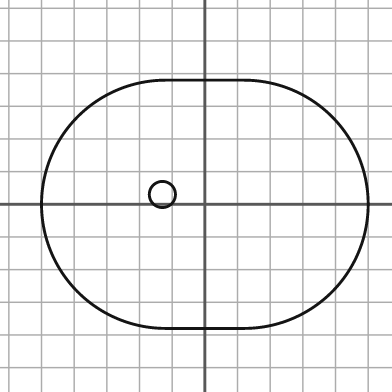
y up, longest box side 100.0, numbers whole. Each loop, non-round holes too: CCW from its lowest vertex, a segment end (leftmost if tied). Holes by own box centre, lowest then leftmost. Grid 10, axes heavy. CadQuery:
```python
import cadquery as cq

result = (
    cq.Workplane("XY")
    .moveTo(-12.0, -38.0)
    .lineTo(12.0, -38.0)
    .threePointArc((50.0, 0.0), (12.0, 38.0))
    .lineTo(-12.0, 38.0)
    .threePointArc((-50.0, 0.0), (-12.0, -38.0))
    .close()
    .moveTo(-13.0, 3.0)
    .circle(4.0)
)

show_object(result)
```